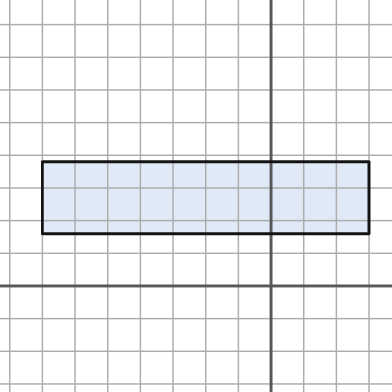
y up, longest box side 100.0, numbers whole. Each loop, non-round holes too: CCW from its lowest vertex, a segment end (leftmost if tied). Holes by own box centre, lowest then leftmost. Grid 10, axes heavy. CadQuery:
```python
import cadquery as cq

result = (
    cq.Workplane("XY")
    .moveTo(-70.0, 16.0)
    .lineTo(30.0, 16.0)
    .lineTo(30.0, 38.0)
    .lineTo(-70.0, 38.0)
    .close()
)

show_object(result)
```